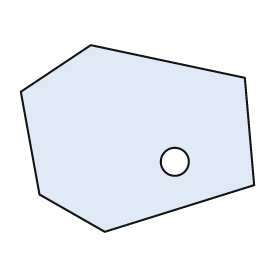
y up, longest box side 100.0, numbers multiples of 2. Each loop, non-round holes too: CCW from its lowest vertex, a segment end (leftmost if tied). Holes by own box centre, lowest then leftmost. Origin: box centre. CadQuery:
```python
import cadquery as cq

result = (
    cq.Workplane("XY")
    .moveTo(-14.0, -40.0)
    .lineTo(50.0, -20.0)
    .lineTo(46.0, 26.0)
    .lineTo(-20.0, 40.0)
    .lineTo(-50.0, 20.0)
    .lineTo(-42.0, -24.0)
    .close()
    .moveTo(16.0, -10.0)
    .circle(6.0)
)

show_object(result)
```